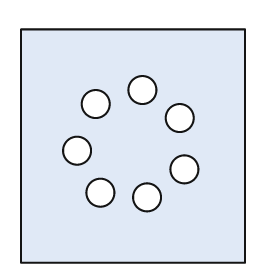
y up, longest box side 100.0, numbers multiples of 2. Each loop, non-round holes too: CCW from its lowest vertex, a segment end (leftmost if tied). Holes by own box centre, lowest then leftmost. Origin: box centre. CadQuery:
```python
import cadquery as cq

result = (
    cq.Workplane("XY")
    .moveTo(-48.0, -50.0)
    .lineTo(48.0, -50.0)
    .lineTo(48.0, 50.0)
    .lineTo(-48.0, 50.0)
    .close()
    .moveTo(6.0, -22.0)
    .circle(6.0)
    .moveTo(-14.0, -20.0)
    .circle(6.0)
    .moveTo(22.0, -10.0)
    .circle(6.0)
    .moveTo(-24.0, -2.0)
    .circle(6.0)
    .moveTo(20.0, 12.0)
    .circle(6.0)
    .moveTo(-16.0, 18.0)
    .circle(6.0)
    .moveTo(4.0, 24.0)
    .circle(6.0)
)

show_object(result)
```